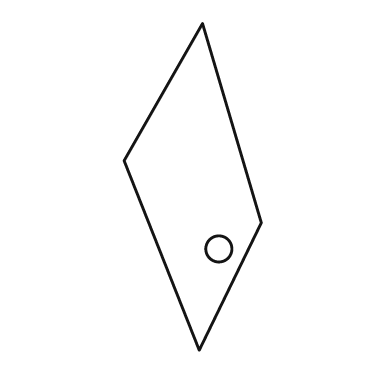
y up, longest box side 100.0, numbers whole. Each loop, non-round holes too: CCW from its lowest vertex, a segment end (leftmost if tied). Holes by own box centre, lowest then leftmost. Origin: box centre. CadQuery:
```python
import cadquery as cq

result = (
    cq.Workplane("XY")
    .moveTo(2.0, -50.0)
    .lineTo(21.0, -11.0)
    .lineTo(3.0, 50.0)
    .lineTo(-21.0, 8.0)
    .close()
    .moveTo(8.0, -19.0)
    .circle(4.0)
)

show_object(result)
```